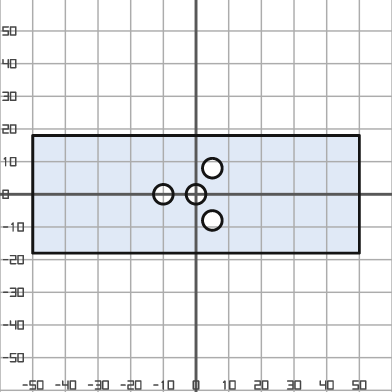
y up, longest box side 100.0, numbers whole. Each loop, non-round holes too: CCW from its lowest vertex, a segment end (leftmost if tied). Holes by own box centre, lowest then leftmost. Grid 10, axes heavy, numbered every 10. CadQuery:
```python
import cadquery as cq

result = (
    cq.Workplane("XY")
    .moveTo(-50.0, -18.0)
    .lineTo(50.0, -18.0)
    .lineTo(50.0, 18.0)
    .lineTo(-50.0, 18.0)
    .close()
    .moveTo(5.0, -8.0)
    .circle(3.0)
    .moveTo(-10.0, 0.0)
    .circle(3.0)
    .moveTo(0.0, 0.0)
    .circle(3.0)
    .moveTo(5.0, 8.0)
    .circle(3.0)
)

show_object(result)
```